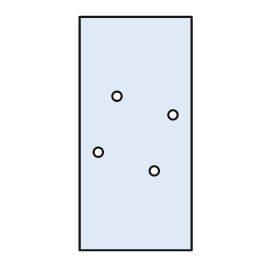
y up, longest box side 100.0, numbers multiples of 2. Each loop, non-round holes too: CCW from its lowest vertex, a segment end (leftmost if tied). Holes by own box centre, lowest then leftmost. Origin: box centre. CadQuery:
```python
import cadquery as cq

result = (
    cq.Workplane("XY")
    .moveTo(-24.0, -50.0)
    .lineTo(24.0, -50.0)
    .lineTo(24.0, 50.0)
    .lineTo(-24.0, 50.0)
    .close()
    .moveTo(8.0, -16.0)
    .circle(2.0)
    .moveTo(-16.0, -8.0)
    .circle(2.0)
    .moveTo(16.0, 8.0)
    .circle(2.0)
    .moveTo(-8.0, 16.0)
    .circle(2.0)
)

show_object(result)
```